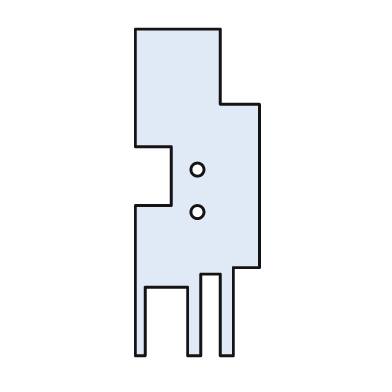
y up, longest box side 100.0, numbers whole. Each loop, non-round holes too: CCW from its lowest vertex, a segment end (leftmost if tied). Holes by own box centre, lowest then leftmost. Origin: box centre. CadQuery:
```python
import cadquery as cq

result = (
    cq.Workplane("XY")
    .moveTo(-19.0, -50.0)
    .lineTo(-16.0, -50.0)
    .lineTo(-16.0, -29.0)
    .lineTo(-3.0, -29.0)
    .lineTo(-3.0, -50.0)
    .lineTo(1.0, -50.0)
    .lineTo(1.0, -25.0)
    .lineTo(7.0, -25.0)
    .lineTo(7.0, -50.0)
    .lineTo(11.0, -50.0)
    .lineTo(11.0, -23.0)
    .lineTo(19.0, -23.0)
    .lineTo(19.0, 27.0)
    .lineTo(7.0, 27.0)
    .lineTo(7.0, 50.0)
    .lineTo(-19.0, 50.0)
    .lineTo(-19.0, 14.0)
    .lineTo(-8.0, 14.0)
    .lineTo(-8.0, -4.0)
    .lineTo(-19.0, -4.0)
    .close()
    .moveTo(0.0, -6.0)
    .circle(2.0)
    .moveTo(0.0, 7.0)
    .circle(2.0)
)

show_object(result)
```